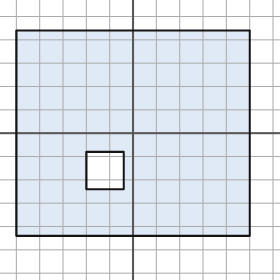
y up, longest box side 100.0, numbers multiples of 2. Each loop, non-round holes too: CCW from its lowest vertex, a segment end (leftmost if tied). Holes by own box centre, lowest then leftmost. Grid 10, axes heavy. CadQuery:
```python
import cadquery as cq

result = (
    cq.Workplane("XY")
    .moveTo(-50.0, -44.0)
    .lineTo(50.0, -44.0)
    .lineTo(50.0, 44.0)
    .lineTo(-50.0, 44.0)
    .close()
    .moveTo(-20.0, -24.0)
    .lineTo(-4.0, -24.0)
    .lineTo(-4.0, -8.0)
    .lineTo(-20.0, -8.0)
    .close()
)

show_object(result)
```